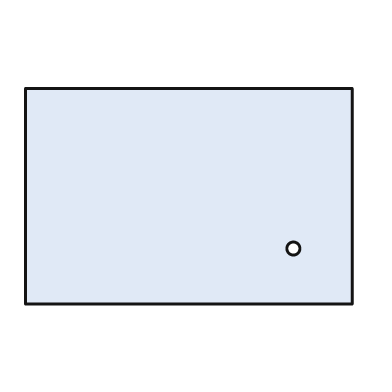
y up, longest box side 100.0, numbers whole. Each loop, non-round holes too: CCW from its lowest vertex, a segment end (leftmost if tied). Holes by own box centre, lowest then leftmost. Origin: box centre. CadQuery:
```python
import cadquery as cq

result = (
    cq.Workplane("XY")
    .moveTo(-50.0, -33.0)
    .lineTo(50.0, -33.0)
    .lineTo(50.0, 33.0)
    .lineTo(-50.0, 33.0)
    .close()
    .moveTo(32.0, -16.0)
    .circle(2.0)
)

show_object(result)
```